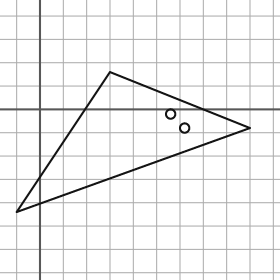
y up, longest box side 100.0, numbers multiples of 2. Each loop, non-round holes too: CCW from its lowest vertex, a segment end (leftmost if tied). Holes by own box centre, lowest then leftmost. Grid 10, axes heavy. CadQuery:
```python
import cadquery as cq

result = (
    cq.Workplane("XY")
    .moveTo(-10.0, -44.0)
    .lineTo(90.0, -8.0)
    .lineTo(30.0, 16.0)
    .close()
    .moveTo(62.0, -8.0)
    .circle(2.0)
    .moveTo(56.0, -2.0)
    .circle(2.0)
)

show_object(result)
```